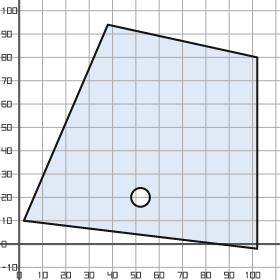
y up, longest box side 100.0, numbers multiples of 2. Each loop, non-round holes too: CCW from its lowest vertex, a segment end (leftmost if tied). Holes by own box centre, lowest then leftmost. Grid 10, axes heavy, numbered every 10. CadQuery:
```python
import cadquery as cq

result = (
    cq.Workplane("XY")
    .moveTo(102.0, -2.0)
    .lineTo(102.0, 80.0)
    .lineTo(38.0, 94.0)
    .lineTo(2.0, 10.0)
    .close()
    .moveTo(52.0, 20.0)
    .circle(4.0)
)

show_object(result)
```